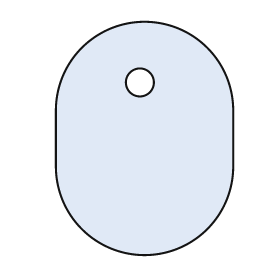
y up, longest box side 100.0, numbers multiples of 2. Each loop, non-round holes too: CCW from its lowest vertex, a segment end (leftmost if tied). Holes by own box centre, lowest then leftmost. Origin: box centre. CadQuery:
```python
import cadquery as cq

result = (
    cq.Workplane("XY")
    .moveTo(-38.0, -12.0)
    .threePointArc((0.0, -50.0), (38.0, -12.0))
    .lineTo(38.0, 12.0)
    .threePointArc((0.0, 50.0), (-38.0, 12.0))
    .close()
    .moveTo(-2.0, 24.0)
    .circle(6.0)
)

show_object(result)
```